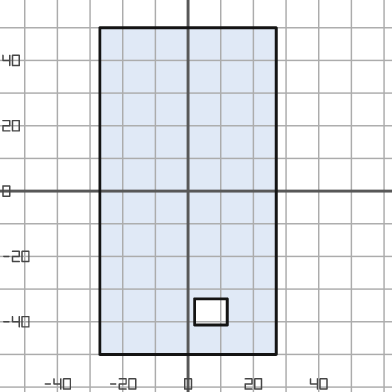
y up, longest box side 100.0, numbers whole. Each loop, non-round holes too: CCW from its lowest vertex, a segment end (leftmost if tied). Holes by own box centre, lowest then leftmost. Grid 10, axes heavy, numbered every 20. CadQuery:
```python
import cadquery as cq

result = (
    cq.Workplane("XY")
    .moveTo(-27.0, -50.0)
    .lineTo(27.0, -50.0)
    .lineTo(27.0, 50.0)
    .lineTo(-27.0, 50.0)
    .close()
    .moveTo(2.0, -41.0)
    .lineTo(12.0, -41.0)
    .lineTo(12.0, -33.0)
    .lineTo(2.0, -33.0)
    .close()
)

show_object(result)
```